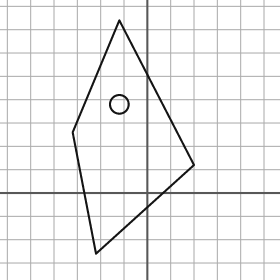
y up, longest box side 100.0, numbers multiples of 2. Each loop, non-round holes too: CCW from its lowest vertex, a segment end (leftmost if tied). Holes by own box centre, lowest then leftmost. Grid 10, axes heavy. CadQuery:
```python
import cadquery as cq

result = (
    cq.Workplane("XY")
    .moveTo(-22.0, -26.0)
    .lineTo(20.0, 12.0)
    .lineTo(-12.0, 74.0)
    .lineTo(-32.0, 26.0)
    .close()
    .moveTo(-12.0, 38.0)
    .circle(4.0)
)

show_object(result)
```